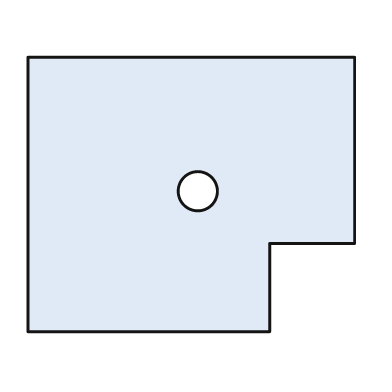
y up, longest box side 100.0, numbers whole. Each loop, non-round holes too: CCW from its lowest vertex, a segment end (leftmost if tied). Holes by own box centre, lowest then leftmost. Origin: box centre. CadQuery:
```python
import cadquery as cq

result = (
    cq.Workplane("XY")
    .moveTo(-50.0, -42.0)
    .lineTo(24.0, -42.0)
    .lineTo(24.0, -15.0)
    .lineTo(50.0, -15.0)
    .lineTo(50.0, 42.0)
    .lineTo(-50.0, 42.0)
    .close()
    .moveTo(2.0, 1.0)
    .circle(6.0)
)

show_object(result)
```